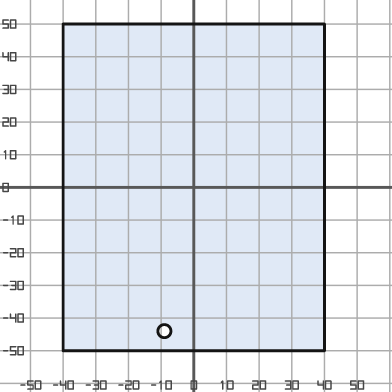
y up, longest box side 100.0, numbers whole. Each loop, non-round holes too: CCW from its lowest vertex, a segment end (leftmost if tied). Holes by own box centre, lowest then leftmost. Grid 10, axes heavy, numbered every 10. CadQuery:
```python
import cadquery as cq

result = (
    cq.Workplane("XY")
    .moveTo(-40.0, -50.0)
    .lineTo(40.0, -50.0)
    .lineTo(40.0, 50.0)
    .lineTo(-40.0, 50.0)
    .close()
    .moveTo(-9.0, -44.0)
    .circle(2.0)
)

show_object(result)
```